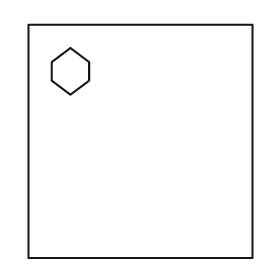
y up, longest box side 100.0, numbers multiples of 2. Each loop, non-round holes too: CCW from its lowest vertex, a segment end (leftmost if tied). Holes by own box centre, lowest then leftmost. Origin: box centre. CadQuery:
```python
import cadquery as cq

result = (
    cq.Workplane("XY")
    .moveTo(-48.0, -50.0)
    .lineTo(48.0, -50.0)
    .lineTo(48.0, 50.0)
    .lineTo(-48.0, 50.0)
    .close()
    .moveTo(-30.0, 20.0)
    .lineTo(-22.0, 26.0)
    .lineTo(-22.0, 34.0)
    .lineTo(-30.0, 40.0)
    .lineTo(-38.0, 34.0)
    .lineTo(-38.0, 26.0)
    .close()
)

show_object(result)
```